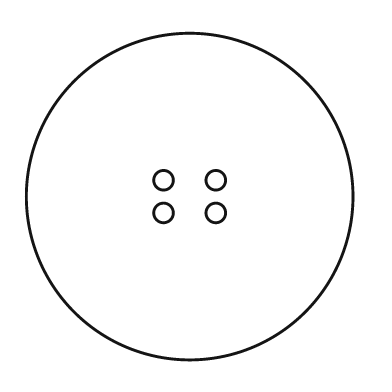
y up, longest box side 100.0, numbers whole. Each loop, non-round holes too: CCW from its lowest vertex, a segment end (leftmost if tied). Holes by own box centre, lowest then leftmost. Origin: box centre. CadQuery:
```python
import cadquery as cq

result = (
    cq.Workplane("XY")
    .moveTo(0.0, 0.0)
    .circle(50.0)
    .moveTo(-8.0, -5.0)
    .circle(3.0)
    .moveTo(8.0, -5.0)
    .circle(3.0)
    .moveTo(-8.0, 5.0)
    .circle(3.0)
    .moveTo(8.0, 5.0)
    .circle(3.0)
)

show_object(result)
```